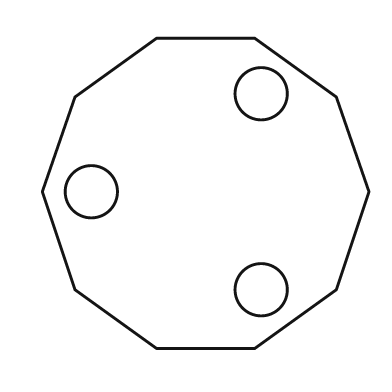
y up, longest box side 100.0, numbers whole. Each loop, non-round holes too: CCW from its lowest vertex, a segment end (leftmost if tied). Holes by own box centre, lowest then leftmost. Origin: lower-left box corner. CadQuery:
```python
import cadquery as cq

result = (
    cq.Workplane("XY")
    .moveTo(35.0, 0.0)
    .lineTo(65.0, 0.0)
    .lineTo(90.0, 18.0)
    .lineTo(100.0, 48.0)
    .lineTo(90.0, 77.0)
    .lineTo(65.0, 95.0)
    .lineTo(35.0, 95.0)
    .lineTo(10.0, 77.0)
    .lineTo(0.0, 48.0)
    .lineTo(10.0, 18.0)
    .close()
    .moveTo(67.0, 18.0)
    .circle(8.0)
    .moveTo(15.0, 48.0)
    .circle(8.0)
    .moveTo(67.0, 78.0)
    .circle(8.0)
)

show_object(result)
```